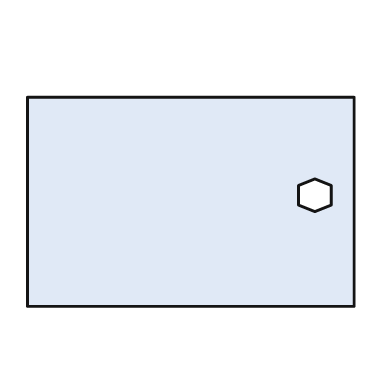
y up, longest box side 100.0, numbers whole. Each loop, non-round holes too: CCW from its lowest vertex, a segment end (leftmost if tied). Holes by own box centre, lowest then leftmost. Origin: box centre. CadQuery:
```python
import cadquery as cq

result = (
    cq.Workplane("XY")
    .moveTo(-50.0, -32.0)
    .lineTo(50.0, -32.0)
    .lineTo(50.0, 32.0)
    .lineTo(-50.0, 32.0)
    .close()
    .moveTo(38.0, -3.0)
    .lineTo(43.0, -1.0)
    .lineTo(43.0, 5.0)
    .lineTo(38.0, 7.0)
    .lineTo(33.0, 5.0)
    .lineTo(33.0, -1.0)
    .close()
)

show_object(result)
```